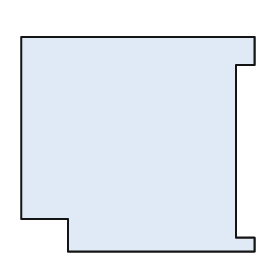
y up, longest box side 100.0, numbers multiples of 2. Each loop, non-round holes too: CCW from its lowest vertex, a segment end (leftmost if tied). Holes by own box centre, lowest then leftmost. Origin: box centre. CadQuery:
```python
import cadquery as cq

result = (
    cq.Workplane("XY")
    .moveTo(-30.0, -46.0)
    .lineTo(50.0, -46.0)
    .lineTo(50.0, -40.0)
    .lineTo(42.0, -40.0)
    .lineTo(42.0, 34.0)
    .lineTo(50.0, 34.0)
    .lineTo(50.0, 46.0)
    .lineTo(-50.0, 46.0)
    .lineTo(-50.0, -32.0)
    .lineTo(-30.0, -32.0)
    .close()
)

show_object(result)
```